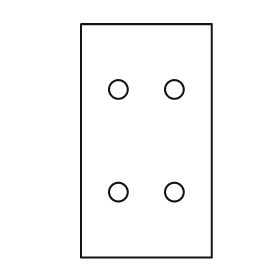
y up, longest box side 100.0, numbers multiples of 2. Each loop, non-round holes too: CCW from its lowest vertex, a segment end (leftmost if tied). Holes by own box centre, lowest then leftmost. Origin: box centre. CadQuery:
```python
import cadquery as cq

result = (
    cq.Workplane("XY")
    .moveTo(-28.0, -50.0)
    .lineTo(28.0, -50.0)
    .lineTo(28.0, 50.0)
    .lineTo(-28.0, 50.0)
    .close()
    .moveTo(-12.0, -22.0)
    .circle(4.0)
    .moveTo(12.0, -22.0)
    .circle(4.0)
    .moveTo(-12.0, 22.0)
    .circle(4.0)
    .moveTo(12.0, 22.0)
    .circle(4.0)
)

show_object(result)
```